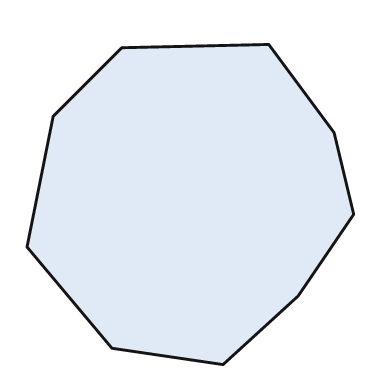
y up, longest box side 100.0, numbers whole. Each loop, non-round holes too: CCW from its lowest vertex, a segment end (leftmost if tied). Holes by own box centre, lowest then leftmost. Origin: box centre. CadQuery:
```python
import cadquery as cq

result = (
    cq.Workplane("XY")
    .moveTo(10.0, -49.0)
    .lineTo(33.0, -28.0)
    .lineTo(50.0, -3.0)
    .lineTo(44.0, 22.0)
    .lineTo(24.0, 49.0)
    .lineTo(-21.0, 48.0)
    .lineTo(-42.0, 27.0)
    .lineTo(-50.0, -13.0)
    .lineTo(-24.0, -44.0)
    .close()
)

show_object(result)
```